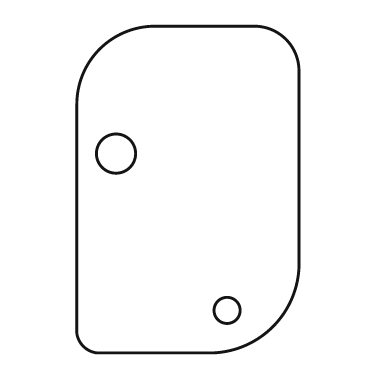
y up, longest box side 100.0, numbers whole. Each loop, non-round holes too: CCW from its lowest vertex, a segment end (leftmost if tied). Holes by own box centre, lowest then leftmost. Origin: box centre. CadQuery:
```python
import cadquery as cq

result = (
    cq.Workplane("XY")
    .moveTo(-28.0, -50.0)
    .lineTo(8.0, -50.0)
    .threePointArc((26.0, -42.0), (34.0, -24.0))
    .lineTo(34.0, 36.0)
    .threePointArc((30.0, 46.0), (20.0, 50.0))
    .lineTo(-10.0, 50.0)
    .threePointArc((-27.0, 43.0), (-34.0, 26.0))
    .lineTo(-34.0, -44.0)
    .threePointArc((-32.0, -48.0), (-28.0, -50.0))
    .close()
    .moveTo(12.0, -37.0)
    .circle(4.0)
    .moveTo(-22.0, 11.0)
    .circle(6.0)
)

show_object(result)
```